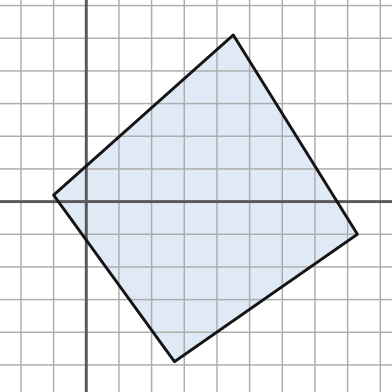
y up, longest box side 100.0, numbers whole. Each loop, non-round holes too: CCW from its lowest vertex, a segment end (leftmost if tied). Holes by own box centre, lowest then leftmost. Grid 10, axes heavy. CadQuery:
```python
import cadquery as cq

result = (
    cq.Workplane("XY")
    .moveTo(27.0, -49.0)
    .lineTo(83.0, -10.0)
    .lineTo(45.0, 51.0)
    .lineTo(-10.0, 2.0)
    .close()
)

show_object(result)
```